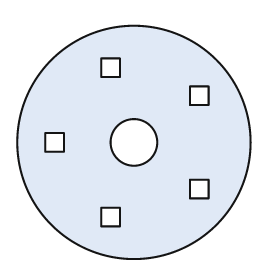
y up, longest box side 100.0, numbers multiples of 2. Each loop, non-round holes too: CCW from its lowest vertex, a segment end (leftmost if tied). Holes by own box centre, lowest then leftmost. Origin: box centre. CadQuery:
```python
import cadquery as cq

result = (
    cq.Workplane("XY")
    .moveTo(0.0, 0.0)
    .circle(50.0)
    .moveTo(-14.0, -36.0)
    .lineTo(-6.0, -36.0)
    .lineTo(-6.0, -28.0)
    .lineTo(-14.0, -28.0)
    .close()
    .moveTo(24.0, -24.0)
    .lineTo(32.0, -24.0)
    .lineTo(32.0, -16.0)
    .lineTo(24.0, -16.0)
    .close()
    .moveTo(-38.0, -4.0)
    .lineTo(-30.0, -4.0)
    .lineTo(-30.0, 4.0)
    .lineTo(-38.0, 4.0)
    .close()
    .moveTo(0.0, 0.0)
    .circle(10.0)
    .moveTo(24.0, 16.0)
    .lineTo(32.0, 16.0)
    .lineTo(32.0, 24.0)
    .lineTo(24.0, 24.0)
    .close()
    .moveTo(-14.0, 28.0)
    .lineTo(-6.0, 28.0)
    .lineTo(-6.0, 36.0)
    .lineTo(-14.0, 36.0)
    .close()
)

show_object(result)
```